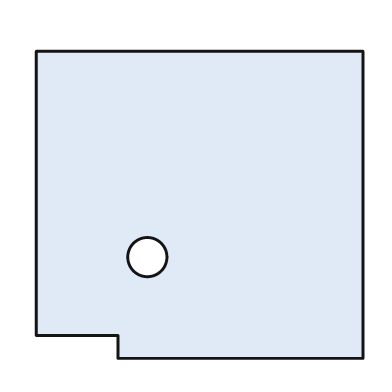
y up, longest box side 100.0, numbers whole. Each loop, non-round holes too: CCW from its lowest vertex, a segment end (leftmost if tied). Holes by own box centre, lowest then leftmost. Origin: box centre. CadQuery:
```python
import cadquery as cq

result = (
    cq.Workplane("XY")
    .moveTo(-25.0, -47.0)
    .lineTo(50.0, -47.0)
    .lineTo(50.0, 47.0)
    .lineTo(-50.0, 47.0)
    .lineTo(-50.0, -40.0)
    .lineTo(-25.0, -40.0)
    .close()
    .moveTo(-16.0, -16.0)
    .circle(6.0)
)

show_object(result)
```